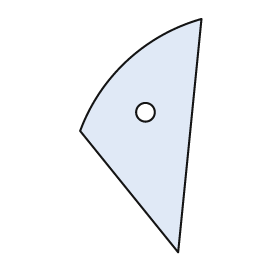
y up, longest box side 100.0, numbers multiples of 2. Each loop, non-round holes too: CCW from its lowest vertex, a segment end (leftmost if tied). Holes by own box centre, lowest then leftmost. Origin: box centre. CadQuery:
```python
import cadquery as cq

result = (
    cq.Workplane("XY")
    .moveTo(16.0, -50.0)
    .lineTo(26.0, 50.0)
    .threePointArc((-6.0, 32.0), (-26.0, 2.0))
    .close()
    .moveTo(2.0, 10.0)
    .circle(4.0)
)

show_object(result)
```